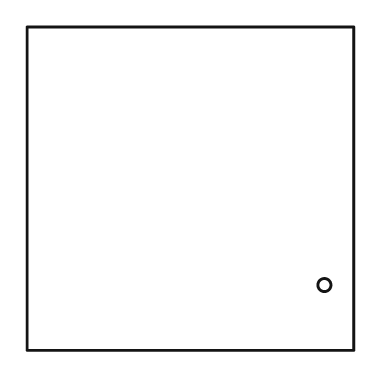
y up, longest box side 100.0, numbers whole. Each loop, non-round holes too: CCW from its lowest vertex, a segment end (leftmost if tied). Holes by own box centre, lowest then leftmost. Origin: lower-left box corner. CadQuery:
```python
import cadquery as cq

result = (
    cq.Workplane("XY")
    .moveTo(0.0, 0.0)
    .lineTo(100.0, 0.0)
    .lineTo(100.0, 99.0)
    .lineTo(0.0, 99.0)
    .close()
    .moveTo(91.0, 20.0)
    .circle(2.0)
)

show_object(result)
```